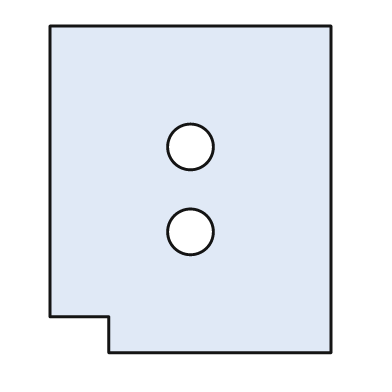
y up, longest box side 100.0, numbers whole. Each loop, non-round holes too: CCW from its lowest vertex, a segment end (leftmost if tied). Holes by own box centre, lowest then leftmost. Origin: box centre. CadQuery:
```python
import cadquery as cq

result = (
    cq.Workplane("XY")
    .moveTo(-25.0, -50.0)
    .lineTo(43.0, -50.0)
    .lineTo(43.0, 50.0)
    .lineTo(-43.0, 50.0)
    .lineTo(-43.0, -39.0)
    .lineTo(-25.0, -39.0)
    .close()
    .moveTo(0.0, -13.0)
    .circle(7.0)
    .moveTo(0.0, 13.0)
    .circle(7.0)
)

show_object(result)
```